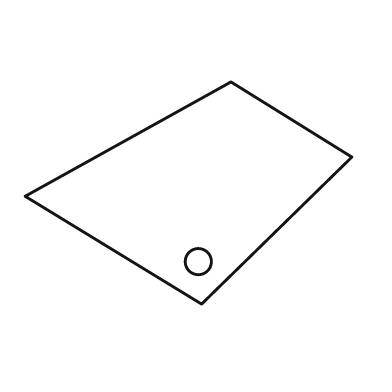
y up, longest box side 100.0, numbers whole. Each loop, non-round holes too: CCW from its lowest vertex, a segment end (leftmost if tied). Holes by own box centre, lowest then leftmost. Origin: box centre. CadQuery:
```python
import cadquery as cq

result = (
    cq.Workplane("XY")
    .moveTo(4.0, -34.0)
    .lineTo(50.0, 11.0)
    .lineTo(13.0, 34.0)
    .lineTo(-50.0, -1.0)
    .close()
    .moveTo(3.0, -21.0)
    .circle(4.0)
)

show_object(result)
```